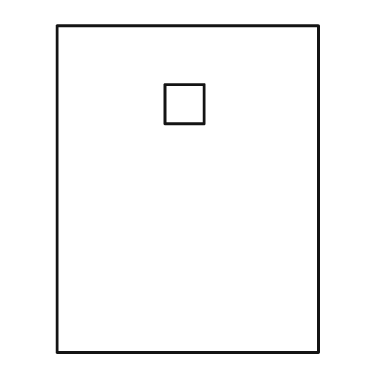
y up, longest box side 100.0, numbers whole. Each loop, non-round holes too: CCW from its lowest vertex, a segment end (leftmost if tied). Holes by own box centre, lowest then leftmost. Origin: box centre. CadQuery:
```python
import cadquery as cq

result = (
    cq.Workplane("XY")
    .moveTo(-40.0, -50.0)
    .lineTo(40.0, -50.0)
    .lineTo(40.0, 50.0)
    .lineTo(-40.0, 50.0)
    .close()
    .moveTo(-7.0, 20.0)
    .lineTo(5.0, 20.0)
    .lineTo(5.0, 32.0)
    .lineTo(-7.0, 32.0)
    .close()
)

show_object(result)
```